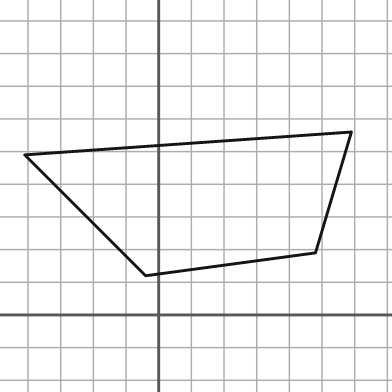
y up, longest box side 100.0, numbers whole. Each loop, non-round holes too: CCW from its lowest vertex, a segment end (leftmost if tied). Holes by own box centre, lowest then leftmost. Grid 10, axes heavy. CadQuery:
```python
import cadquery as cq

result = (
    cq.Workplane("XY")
    .moveTo(-4.0, 12.0)
    .lineTo(48.0, 19.0)
    .lineTo(59.0, 56.0)
    .lineTo(-41.0, 49.0)
    .close()
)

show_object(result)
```